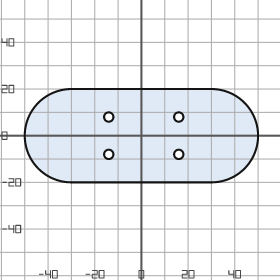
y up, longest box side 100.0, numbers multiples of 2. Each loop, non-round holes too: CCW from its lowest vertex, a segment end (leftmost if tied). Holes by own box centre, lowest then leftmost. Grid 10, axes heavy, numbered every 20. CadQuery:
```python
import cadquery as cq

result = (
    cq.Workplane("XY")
    .moveTo(-30.0, -20.0)
    .lineTo(30.0, -20.0)
    .threePointArc((50.0, 0.0), (30.0, 20.0))
    .lineTo(-30.0, 20.0)
    .threePointArc((-50.0, 0.0), (-30.0, -20.0))
    .close()
    .moveTo(-14.0, -8.0)
    .circle(2.0)
    .moveTo(16.0, -8.0)
    .circle(2.0)
    .moveTo(-14.0, 8.0)
    .circle(2.0)
    .moveTo(16.0, 8.0)
    .circle(2.0)
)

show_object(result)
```